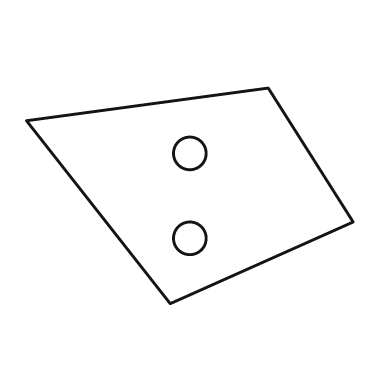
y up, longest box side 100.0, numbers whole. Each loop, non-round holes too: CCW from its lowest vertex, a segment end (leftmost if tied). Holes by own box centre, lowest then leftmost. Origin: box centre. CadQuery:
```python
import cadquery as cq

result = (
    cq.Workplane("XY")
    .moveTo(-6.0, -33.0)
    .lineTo(50.0, -8.0)
    .lineTo(24.0, 33.0)
    .lineTo(-50.0, 23.0)
    .close()
    .moveTo(0.0, -13.0)
    .circle(5.0)
    .moveTo(0.0, 13.0)
    .circle(5.0)
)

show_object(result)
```